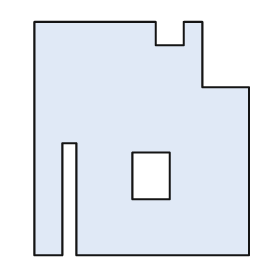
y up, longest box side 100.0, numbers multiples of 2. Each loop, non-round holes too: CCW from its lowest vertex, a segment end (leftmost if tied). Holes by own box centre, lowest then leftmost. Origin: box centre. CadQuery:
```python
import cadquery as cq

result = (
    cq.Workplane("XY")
    .moveTo(-46.0, -50.0)
    .lineTo(-34.0, -50.0)
    .lineTo(-34.0, -2.0)
    .lineTo(-28.0, -2.0)
    .lineTo(-28.0, -50.0)
    .lineTo(46.0, -50.0)
    .lineTo(46.0, 22.0)
    .lineTo(26.0, 22.0)
    .lineTo(26.0, 50.0)
    .lineTo(18.0, 50.0)
    .lineTo(18.0, 40.0)
    .lineTo(6.0, 40.0)
    .lineTo(6.0, 50.0)
    .lineTo(-46.0, 50.0)
    .close()
    .moveTo(-4.0, -26.0)
    .lineTo(12.0, -26.0)
    .lineTo(12.0, -6.0)
    .lineTo(-4.0, -6.0)
    .close()
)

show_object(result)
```